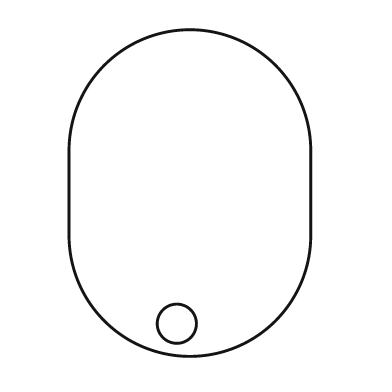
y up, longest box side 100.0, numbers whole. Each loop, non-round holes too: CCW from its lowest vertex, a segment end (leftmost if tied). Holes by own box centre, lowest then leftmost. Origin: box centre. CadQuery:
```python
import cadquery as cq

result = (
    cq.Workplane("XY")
    .moveTo(-37.0, -13.0)
    .threePointArc((0.0, -50.0), (37.0, -13.0))
    .lineTo(37.0, 13.0)
    .threePointArc((0.0, 50.0), (-37.0, 13.0))
    .close()
    .moveTo(-4.0, -40.0)
    .circle(6.0)
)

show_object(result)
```